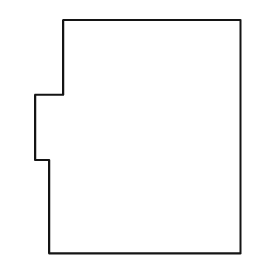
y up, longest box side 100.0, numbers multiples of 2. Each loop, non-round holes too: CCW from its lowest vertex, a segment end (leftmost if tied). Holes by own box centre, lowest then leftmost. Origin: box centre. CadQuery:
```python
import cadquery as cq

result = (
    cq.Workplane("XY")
    .moveTo(-38.0, -50.0)
    .lineTo(44.0, -50.0)
    .lineTo(44.0, 50.0)
    .lineTo(-32.0, 50.0)
    .lineTo(-32.0, 18.0)
    .lineTo(-44.0, 18.0)
    .lineTo(-44.0, -10.0)
    .lineTo(-38.0, -10.0)
    .close()
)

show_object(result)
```